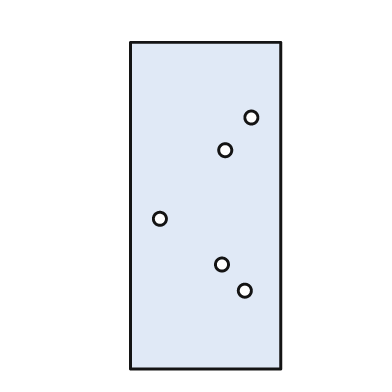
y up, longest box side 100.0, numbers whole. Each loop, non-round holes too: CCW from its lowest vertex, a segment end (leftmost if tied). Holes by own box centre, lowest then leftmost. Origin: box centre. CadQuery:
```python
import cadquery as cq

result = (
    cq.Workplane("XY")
    .moveTo(-23.0, -50.0)
    .lineTo(23.0, -50.0)
    .lineTo(23.0, 50.0)
    .lineTo(-23.0, 50.0)
    .close()
    .moveTo(12.0, -26.0)
    .circle(2.0)
    .moveTo(5.0, -18.0)
    .circle(2.0)
    .moveTo(-14.0, -4.0)
    .circle(2.0)
    .moveTo(6.0, 17.0)
    .circle(2.0)
    .moveTo(14.0, 27.0)
    .circle(2.0)
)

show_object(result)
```